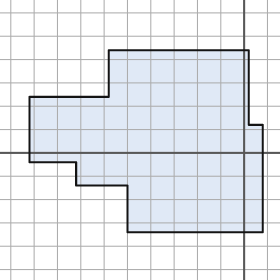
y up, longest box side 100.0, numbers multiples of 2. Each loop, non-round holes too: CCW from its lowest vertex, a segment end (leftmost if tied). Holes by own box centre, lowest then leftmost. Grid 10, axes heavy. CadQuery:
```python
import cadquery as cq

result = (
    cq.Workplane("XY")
    .moveTo(-50.0, -34.0)
    .lineTo(8.0, -34.0)
    .lineTo(8.0, 12.0)
    .lineTo(2.0, 12.0)
    .lineTo(2.0, 44.0)
    .lineTo(-58.0, 44.0)
    .lineTo(-58.0, 24.0)
    .lineTo(-92.0, 24.0)
    .lineTo(-92.0, -4.0)
    .lineTo(-72.0, -4.0)
    .lineTo(-72.0, -14.0)
    .lineTo(-50.0, -14.0)
    .close()
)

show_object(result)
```